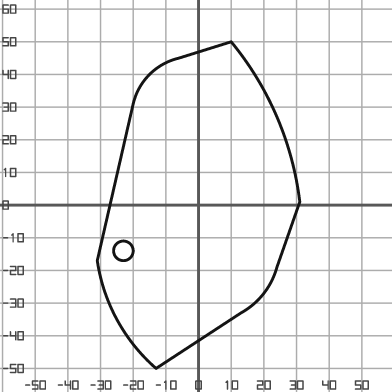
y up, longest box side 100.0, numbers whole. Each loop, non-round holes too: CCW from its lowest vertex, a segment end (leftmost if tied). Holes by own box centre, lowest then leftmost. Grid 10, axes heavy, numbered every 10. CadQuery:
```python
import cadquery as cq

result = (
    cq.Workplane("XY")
    .moveTo(-13.0, -50.0)
    .lineTo(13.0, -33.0)
    .threePointArc((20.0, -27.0), (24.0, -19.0))
    .lineTo(31.0, 1.0)
    .threePointArc((24.0, 27.0), (10.0, 50.0))
    .lineTo(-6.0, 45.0)
    .threePointArc((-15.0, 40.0), (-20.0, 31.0))
    .lineTo(-31.0, -17.0)
    .threePointArc((-25.0, -35.0), (-13.0, -50.0))
    .close()
    .moveTo(-23.0, -14.0)
    .circle(3.0)
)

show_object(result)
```